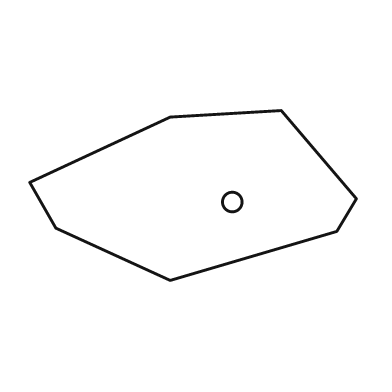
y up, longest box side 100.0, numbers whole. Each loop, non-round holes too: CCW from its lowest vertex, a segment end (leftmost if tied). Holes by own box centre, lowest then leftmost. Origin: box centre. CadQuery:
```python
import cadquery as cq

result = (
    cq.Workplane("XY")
    .moveTo(-7.0, -26.0)
    .lineTo(44.0, -11.0)
    .lineTo(50.0, -1.0)
    .lineTo(27.0, 26.0)
    .lineTo(-7.0, 24.0)
    .lineTo(-50.0, 4.0)
    .lineTo(-42.0, -10.0)
    .close()
    .moveTo(12.0, -2.0)
    .circle(3.0)
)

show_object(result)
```